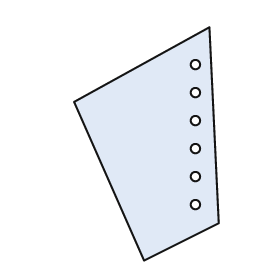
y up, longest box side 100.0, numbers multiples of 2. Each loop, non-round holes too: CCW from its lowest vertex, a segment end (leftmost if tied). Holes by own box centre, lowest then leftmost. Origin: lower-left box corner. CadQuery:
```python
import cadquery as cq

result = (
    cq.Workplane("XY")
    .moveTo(30.0, 0.0)
    .lineTo(62.0, 16.0)
    .lineTo(58.0, 100.0)
    .lineTo(0.0, 68.0)
    .close()
    .moveTo(52.0, 24.0)
    .circle(2.0)
    .moveTo(52.0, 36.0)
    .circle(2.0)
    .moveTo(52.0, 48.0)
    .circle(2.0)
    .moveTo(52.0, 60.0)
    .circle(2.0)
    .moveTo(52.0, 72.0)
    .circle(2.0)
    .moveTo(52.0, 84.0)
    .circle(2.0)
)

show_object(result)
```